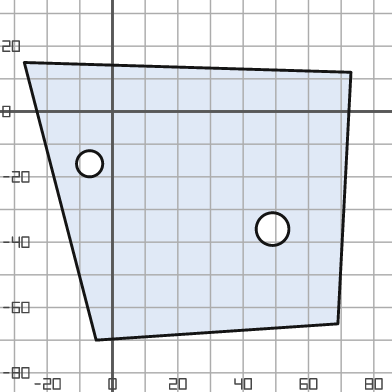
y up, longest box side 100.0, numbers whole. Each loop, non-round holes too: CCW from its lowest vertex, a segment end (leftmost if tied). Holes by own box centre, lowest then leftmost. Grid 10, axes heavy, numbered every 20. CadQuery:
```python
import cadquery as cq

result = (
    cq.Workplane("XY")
    .moveTo(-5.0, -70.0)
    .lineTo(69.0, -65.0)
    .lineTo(73.0, 12.0)
    .lineTo(-27.0, 15.0)
    .close()
    .moveTo(49.0, -36.0)
    .circle(5.0)
    .moveTo(-7.0, -16.0)
    .circle(4.0)
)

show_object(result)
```